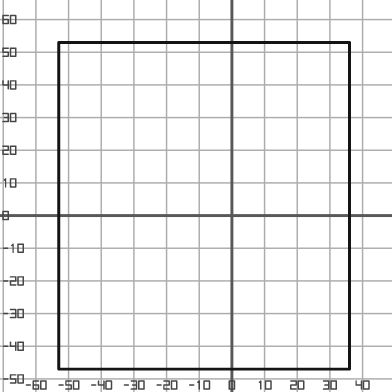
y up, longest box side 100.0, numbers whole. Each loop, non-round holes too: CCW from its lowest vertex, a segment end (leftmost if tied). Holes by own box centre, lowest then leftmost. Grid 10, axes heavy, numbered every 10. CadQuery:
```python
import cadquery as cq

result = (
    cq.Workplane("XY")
    .moveTo(-53.0, -47.0)
    .lineTo(36.0, -47.0)
    .lineTo(36.0, 53.0)
    .lineTo(-53.0, 53.0)
    .close()
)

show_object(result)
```